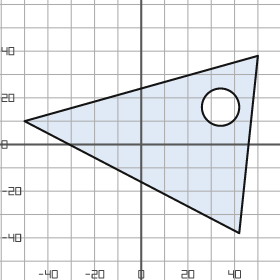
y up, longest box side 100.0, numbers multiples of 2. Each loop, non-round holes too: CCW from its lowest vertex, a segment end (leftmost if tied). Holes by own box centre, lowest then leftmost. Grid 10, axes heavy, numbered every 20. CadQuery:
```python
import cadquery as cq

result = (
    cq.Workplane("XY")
    .moveTo(42.0, -38.0)
    .lineTo(50.0, 38.0)
    .lineTo(-50.0, 10.0)
    .close()
    .moveTo(34.0, 16.0)
    .circle(8.0)
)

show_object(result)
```